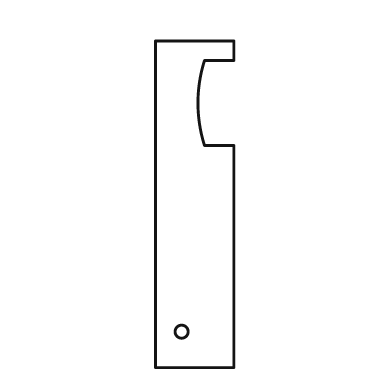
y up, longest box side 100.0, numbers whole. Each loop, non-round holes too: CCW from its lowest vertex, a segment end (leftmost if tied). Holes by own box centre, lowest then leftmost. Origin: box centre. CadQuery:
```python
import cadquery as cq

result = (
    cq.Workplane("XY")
    .moveTo(-12.0, -50.0)
    .lineTo(12.0, -50.0)
    .lineTo(12.0, 18.0)
    .lineTo(3.0, 18.0)
    .threePointArc((1.0, 31.0), (3.0, 44.0))
    .lineTo(12.0, 44.0)
    .lineTo(12.0, 50.0)
    .lineTo(-12.0, 50.0)
    .close()
    .moveTo(-4.0, -39.0)
    .circle(2.0)
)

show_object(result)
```